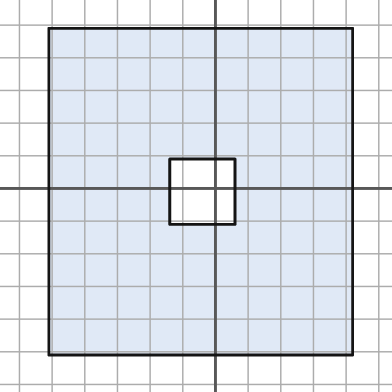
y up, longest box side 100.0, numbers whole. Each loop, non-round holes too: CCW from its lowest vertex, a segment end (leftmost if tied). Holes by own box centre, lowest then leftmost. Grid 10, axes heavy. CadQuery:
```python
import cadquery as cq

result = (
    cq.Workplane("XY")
    .moveTo(-51.0, -51.0)
    .lineTo(42.0, -51.0)
    .lineTo(42.0, 49.0)
    .lineTo(-51.0, 49.0)
    .close()
    .moveTo(-14.0, -11.0)
    .lineTo(6.0, -11.0)
    .lineTo(6.0, 9.0)
    .lineTo(-14.0, 9.0)
    .close()
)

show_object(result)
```